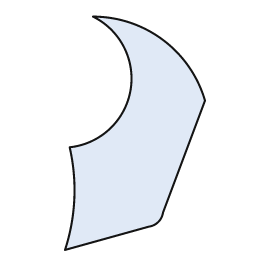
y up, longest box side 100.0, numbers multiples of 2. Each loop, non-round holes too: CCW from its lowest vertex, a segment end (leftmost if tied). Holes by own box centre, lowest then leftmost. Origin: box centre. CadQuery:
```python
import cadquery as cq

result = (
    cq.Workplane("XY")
    .moveTo(-30.0, -50.0)
    .lineTo(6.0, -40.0)
    .threePointArc((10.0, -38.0), (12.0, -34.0))
    .lineTo(30.0, 14.0)
    .threePointArc((12.0, 40.0), (-18.0, 50.0))
    .threePointArc((-2.0, 18.0), (-28.0, -6.0))
    .threePointArc((-26.0, -28.0), (-30.0, -50.0))
    .close()
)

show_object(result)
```